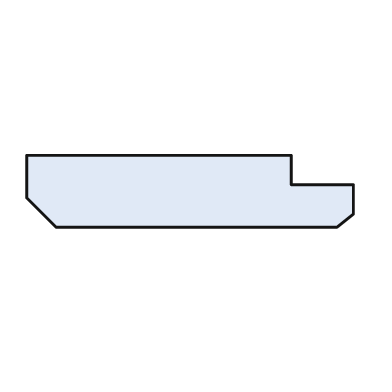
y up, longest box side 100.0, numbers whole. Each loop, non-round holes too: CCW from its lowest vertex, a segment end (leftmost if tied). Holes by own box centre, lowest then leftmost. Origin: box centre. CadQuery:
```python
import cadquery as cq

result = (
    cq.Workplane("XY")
    .moveTo(-41.0, -11.0)
    .lineTo(45.0, -11.0)
    .lineTo(50.0, -7.0)
    .lineTo(50.0, 2.0)
    .lineTo(31.0, 2.0)
    .lineTo(31.0, 11.0)
    .lineTo(-50.0, 11.0)
    .lineTo(-50.0, -2.0)
    .close()
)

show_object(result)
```